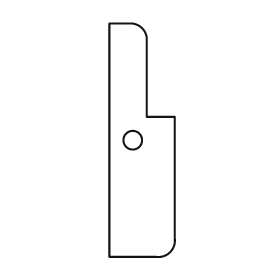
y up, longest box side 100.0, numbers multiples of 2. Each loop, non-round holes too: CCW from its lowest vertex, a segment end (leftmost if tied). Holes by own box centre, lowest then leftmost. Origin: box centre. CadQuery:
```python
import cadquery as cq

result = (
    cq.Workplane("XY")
    .moveTo(-14.0, -50.0)
    .lineTo(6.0, -50.0)
    .threePointArc((12.0, -48.0), (14.0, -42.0))
    .lineTo(14.0, 10.0)
    .lineTo(2.0, 10.0)
    .lineTo(2.0, 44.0)
    .threePointArc((0.0, 48.0), (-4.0, 50.0))
    .lineTo(-14.0, 50.0)
    .close()
    .moveTo(-4.0, 0.0)
    .circle(4.0)
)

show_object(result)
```